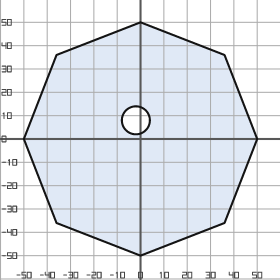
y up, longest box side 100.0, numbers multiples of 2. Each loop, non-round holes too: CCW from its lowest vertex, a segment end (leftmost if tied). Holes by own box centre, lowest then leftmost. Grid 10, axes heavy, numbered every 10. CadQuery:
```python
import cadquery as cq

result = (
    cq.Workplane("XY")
    .moveTo(0.0, -50.0)
    .lineTo(36.0, -36.0)
    .lineTo(50.0, 0.0)
    .lineTo(36.0, 36.0)
    .lineTo(0.0, 50.0)
    .lineTo(-36.0, 36.0)
    .lineTo(-50.0, 0.0)
    .lineTo(-36.0, -36.0)
    .close()
    .moveTo(-2.0, 8.0)
    .circle(6.0)
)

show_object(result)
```